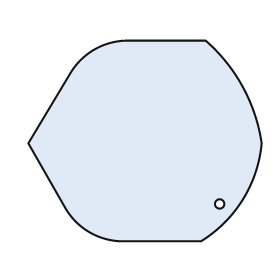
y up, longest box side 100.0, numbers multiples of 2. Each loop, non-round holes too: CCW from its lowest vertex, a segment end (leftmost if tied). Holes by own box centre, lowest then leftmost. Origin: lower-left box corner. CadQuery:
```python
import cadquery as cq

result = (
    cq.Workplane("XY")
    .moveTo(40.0, 0.0)
    .lineTo(74.0, 0.0)
    .threePointArc((92.0, 18.0), (100.0, 42.0))
    .threePointArc((92.0, 66.0), (76.0, 86.0))
    .lineTo(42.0, 86.0)
    .threePointArc((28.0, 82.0), (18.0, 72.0))
    .lineTo(0.0, 42.0)
    .lineTo(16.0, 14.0)
    .threePointArc((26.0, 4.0), (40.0, 0.0))
    .close()
    .moveTo(82.0, 16.0)
    .circle(2.0)
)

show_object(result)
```